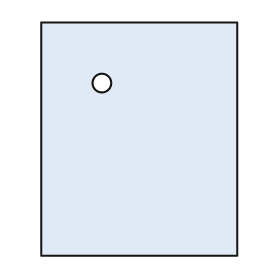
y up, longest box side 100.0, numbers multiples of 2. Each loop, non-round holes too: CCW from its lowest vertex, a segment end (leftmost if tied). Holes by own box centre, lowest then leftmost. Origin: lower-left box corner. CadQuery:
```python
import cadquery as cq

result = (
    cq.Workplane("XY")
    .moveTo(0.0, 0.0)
    .lineTo(84.0, 0.0)
    .lineTo(84.0, 100.0)
    .lineTo(0.0, 100.0)
    .close()
    .moveTo(26.0, 74.0)
    .circle(4.0)
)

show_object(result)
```